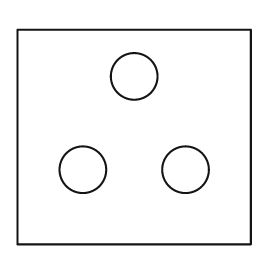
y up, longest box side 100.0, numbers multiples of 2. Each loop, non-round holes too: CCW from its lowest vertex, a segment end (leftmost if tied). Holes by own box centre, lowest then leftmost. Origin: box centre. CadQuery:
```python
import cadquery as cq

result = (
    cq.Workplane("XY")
    .moveTo(-50.0, -46.0)
    .lineTo(50.0, -46.0)
    .lineTo(50.0, 46.0)
    .lineTo(-50.0, 46.0)
    .close()
    .moveTo(-22.0, -14.0)
    .circle(10.0)
    .moveTo(22.0, -14.0)
    .circle(10.0)
    .moveTo(0.0, 26.0)
    .circle(10.0)
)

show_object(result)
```